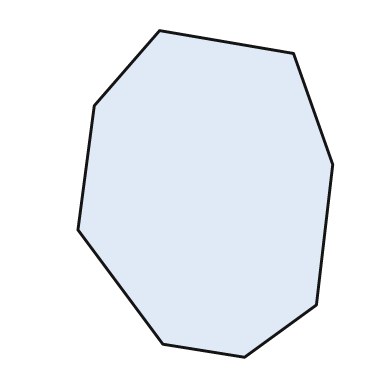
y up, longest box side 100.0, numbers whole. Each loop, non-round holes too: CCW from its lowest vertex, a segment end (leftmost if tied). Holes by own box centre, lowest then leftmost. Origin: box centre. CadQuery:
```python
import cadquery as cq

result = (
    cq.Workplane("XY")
    .moveTo(12.0, -50.0)
    .lineTo(34.0, -34.0)
    .lineTo(39.0, 9.0)
    .lineTo(27.0, 43.0)
    .lineTo(-14.0, 50.0)
    .lineTo(-34.0, 27.0)
    .lineTo(-39.0, -11.0)
    .lineTo(-13.0, -46.0)
    .close()
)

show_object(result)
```